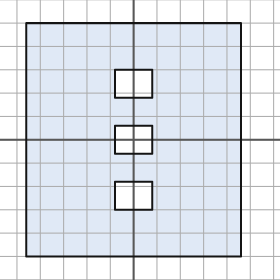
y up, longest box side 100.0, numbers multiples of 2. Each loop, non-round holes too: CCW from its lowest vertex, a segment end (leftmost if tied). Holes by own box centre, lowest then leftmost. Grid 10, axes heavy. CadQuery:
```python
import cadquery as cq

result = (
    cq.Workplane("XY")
    .moveTo(-46.0, -50.0)
    .lineTo(46.0, -50.0)
    .lineTo(46.0, 50.0)
    .lineTo(-46.0, 50.0)
    .close()
    .moveTo(-8.0, -30.0)
    .lineTo(8.0, -30.0)
    .lineTo(8.0, -18.0)
    .lineTo(-8.0, -18.0)
    .close()
    .moveTo(-8.0, -6.0)
    .lineTo(8.0, -6.0)
    .lineTo(8.0, 6.0)
    .lineTo(-8.0, 6.0)
    .close()
    .moveTo(-8.0, 18.0)
    .lineTo(8.0, 18.0)
    .lineTo(8.0, 30.0)
    .lineTo(-8.0, 30.0)
    .close()
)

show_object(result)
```